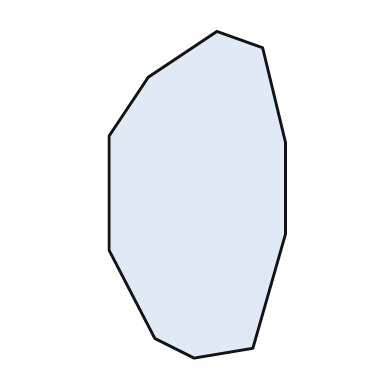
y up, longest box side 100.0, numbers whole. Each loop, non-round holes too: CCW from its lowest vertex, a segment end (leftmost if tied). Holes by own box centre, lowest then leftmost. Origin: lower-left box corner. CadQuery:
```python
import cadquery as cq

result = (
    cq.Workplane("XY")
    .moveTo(26.0, 0.0)
    .lineTo(44.0, 3.0)
    .lineTo(54.0, 38.0)
    .lineTo(54.0, 66.0)
    .lineTo(47.0, 95.0)
    .lineTo(33.0, 100.0)
    .lineTo(12.0, 86.0)
    .lineTo(0.0, 68.0)
    .lineTo(0.0, 33.0)
    .lineTo(14.0, 6.0)
    .close()
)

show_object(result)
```